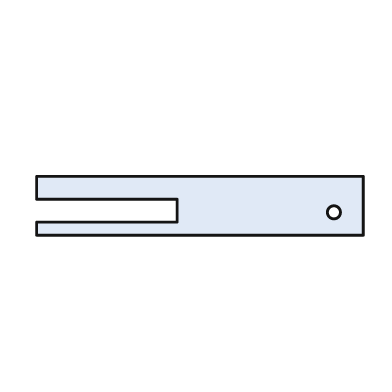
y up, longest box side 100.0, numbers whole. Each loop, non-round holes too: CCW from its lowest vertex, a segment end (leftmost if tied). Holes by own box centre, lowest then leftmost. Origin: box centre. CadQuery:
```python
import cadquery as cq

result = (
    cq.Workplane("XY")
    .moveTo(-50.0, -9.0)
    .lineTo(50.0, -9.0)
    .lineTo(50.0, 9.0)
    .lineTo(-50.0, 9.0)
    .lineTo(-50.0, 2.0)
    .lineTo(-7.0, 2.0)
    .lineTo(-7.0, -5.0)
    .lineTo(-50.0, -5.0)
    .close()
    .moveTo(41.0, -2.0)
    .circle(2.0)
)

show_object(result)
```